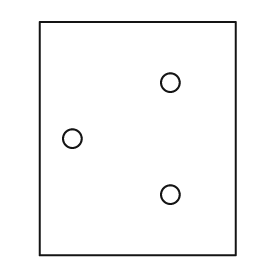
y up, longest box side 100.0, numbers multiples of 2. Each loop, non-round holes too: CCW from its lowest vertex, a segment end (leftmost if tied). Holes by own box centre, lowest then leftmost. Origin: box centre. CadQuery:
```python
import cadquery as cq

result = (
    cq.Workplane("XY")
    .moveTo(-42.0, -50.0)
    .lineTo(42.0, -50.0)
    .lineTo(42.0, 50.0)
    .lineTo(-42.0, 50.0)
    .close()
    .moveTo(14.0, -24.0)
    .circle(4.0)
    .moveTo(-28.0, 0.0)
    .circle(4.0)
    .moveTo(14.0, 24.0)
    .circle(4.0)
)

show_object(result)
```